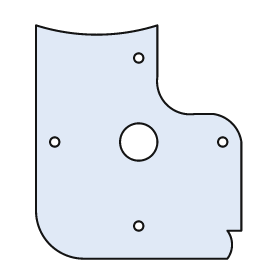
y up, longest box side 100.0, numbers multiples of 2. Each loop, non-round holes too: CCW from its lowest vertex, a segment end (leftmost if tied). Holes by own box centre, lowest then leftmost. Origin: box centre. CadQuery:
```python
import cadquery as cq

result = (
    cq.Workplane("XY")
    .moveTo(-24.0, -50.0)
    .lineTo(38.0, -50.0)
    .threePointArc((40.0, -44.0), (38.0, -38.0))
    .lineTo(44.0, -38.0)
    .lineTo(44.0, 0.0)
    .threePointArc((40.0, 8.0), (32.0, 12.0))
    .lineTo(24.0, 12.0)
    .threePointArc((12.0, 16.0), (8.0, 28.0))
    .lineTo(8.0, 50.0)
    .threePointArc((-18.0, 46.0), (-44.0, 50.0))
    .lineTo(-44.0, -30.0)
    .threePointArc((-38.0, -44.0), (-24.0, -50.0))
    .close()
    .moveTo(0.0, -36.0)
    .circle(2.0)
    .moveTo(-36.0, 0.0)
    .circle(2.0)
    .moveTo(0.0, 0.0)
    .circle(8.0)
    .moveTo(36.0, 0.0)
    .circle(2.0)
    .moveTo(0.0, 36.0)
    .circle(2.0)
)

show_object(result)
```